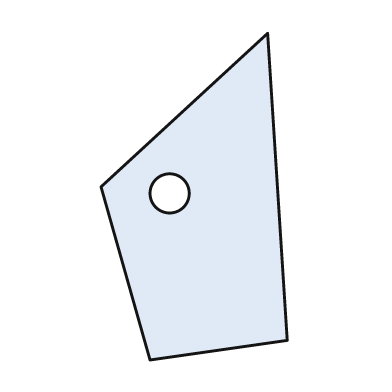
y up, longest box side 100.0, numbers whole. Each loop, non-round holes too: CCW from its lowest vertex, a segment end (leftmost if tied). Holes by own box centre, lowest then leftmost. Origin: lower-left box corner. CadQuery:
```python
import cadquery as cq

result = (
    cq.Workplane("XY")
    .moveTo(15.0, 0.0)
    .lineTo(57.0, 6.0)
    .lineTo(51.0, 100.0)
    .lineTo(0.0, 53.0)
    .close()
    .moveTo(21.0, 51.0)
    .circle(6.0)
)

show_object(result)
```